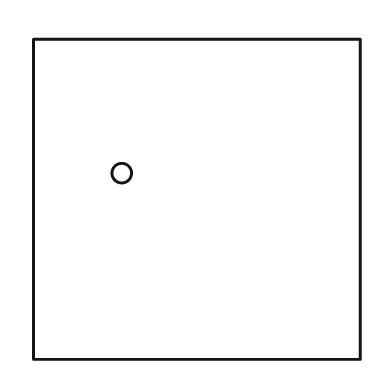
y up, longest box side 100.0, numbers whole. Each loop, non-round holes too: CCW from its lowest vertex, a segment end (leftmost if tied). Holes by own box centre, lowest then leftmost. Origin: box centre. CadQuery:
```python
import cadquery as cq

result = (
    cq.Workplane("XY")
    .moveTo(-50.0, -49.0)
    .lineTo(50.0, -49.0)
    .lineTo(50.0, 49.0)
    .lineTo(-50.0, 49.0)
    .close()
    .moveTo(-23.0, 8.0)
    .circle(3.0)
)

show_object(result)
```